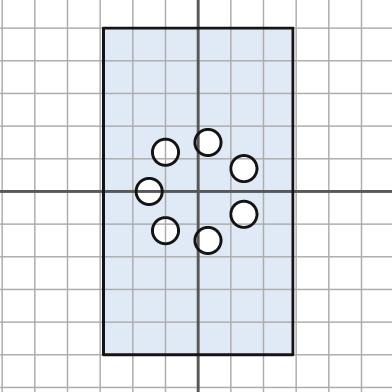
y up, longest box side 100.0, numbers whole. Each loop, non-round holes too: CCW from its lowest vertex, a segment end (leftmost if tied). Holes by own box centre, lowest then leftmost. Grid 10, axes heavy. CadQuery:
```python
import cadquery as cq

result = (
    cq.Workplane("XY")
    .moveTo(-29.0, -50.0)
    .lineTo(29.0, -50.0)
    .lineTo(29.0, 50.0)
    .lineTo(-29.0, 50.0)
    .close()
    .moveTo(3.0, -15.0)
    .circle(4.0)
    .moveTo(-10.0, -12.0)
    .circle(4.0)
    .moveTo(14.0, -7.0)
    .circle(4.0)
    .moveTo(-15.0, 0.0)
    .circle(4.0)
    .moveTo(14.0, 7.0)
    .circle(4.0)
    .moveTo(-10.0, 12.0)
    .circle(4.0)
    .moveTo(3.0, 15.0)
    .circle(4.0)
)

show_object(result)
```